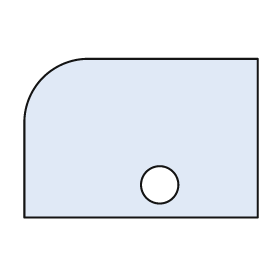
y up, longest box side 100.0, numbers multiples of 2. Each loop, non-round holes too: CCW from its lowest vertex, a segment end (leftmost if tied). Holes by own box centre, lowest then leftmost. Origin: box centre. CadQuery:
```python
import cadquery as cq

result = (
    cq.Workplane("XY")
    .moveTo(-50.0, -34.0)
    .lineTo(50.0, -34.0)
    .lineTo(50.0, 34.0)
    .lineTo(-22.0, 34.0)
    .threePointArc((-42.0, 26.0), (-50.0, 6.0))
    .close()
    .moveTo(8.0, -20.0)
    .circle(8.0)
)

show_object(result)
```